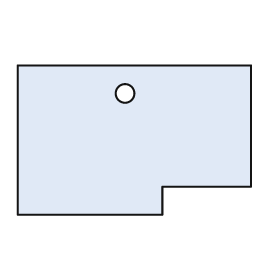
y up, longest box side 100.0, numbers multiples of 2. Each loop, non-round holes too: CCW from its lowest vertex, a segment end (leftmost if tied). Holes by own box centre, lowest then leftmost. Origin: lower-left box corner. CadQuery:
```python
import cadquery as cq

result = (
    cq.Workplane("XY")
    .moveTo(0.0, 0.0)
    .lineTo(62.0, 0.0)
    .lineTo(62.0, 12.0)
    .lineTo(100.0, 12.0)
    .lineTo(100.0, 64.0)
    .lineTo(0.0, 64.0)
    .close()
    .moveTo(46.0, 52.0)
    .circle(4.0)
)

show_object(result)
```